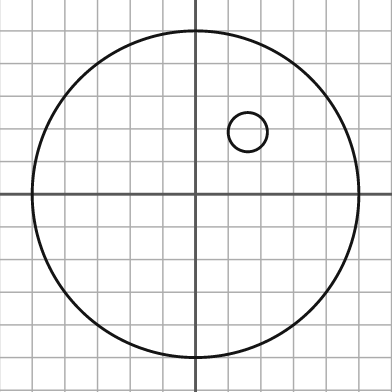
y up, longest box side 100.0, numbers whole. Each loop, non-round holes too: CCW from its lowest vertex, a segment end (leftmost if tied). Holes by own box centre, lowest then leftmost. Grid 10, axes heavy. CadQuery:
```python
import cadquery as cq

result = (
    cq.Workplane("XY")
    .moveTo(0.0, 0.0)
    .circle(50.0)
    .moveTo(16.0, 19.0)
    .circle(6.0)
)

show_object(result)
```